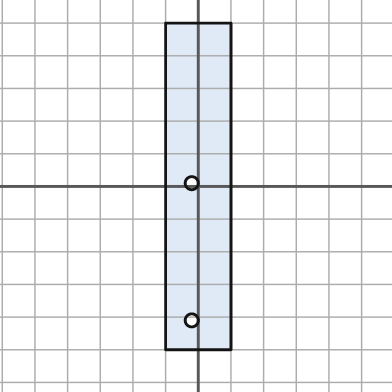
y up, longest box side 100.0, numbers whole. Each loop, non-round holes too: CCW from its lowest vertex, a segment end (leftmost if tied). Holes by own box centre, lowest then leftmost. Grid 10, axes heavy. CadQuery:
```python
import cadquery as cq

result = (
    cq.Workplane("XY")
    .moveTo(-10.0, -50.0)
    .lineTo(10.0, -50.0)
    .lineTo(10.0, 50.0)
    .lineTo(-10.0, 50.0)
    .close()
    .moveTo(-2.0, -41.0)
    .circle(2.0)
    .moveTo(-2.0, 1.0)
    .circle(2.0)
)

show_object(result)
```